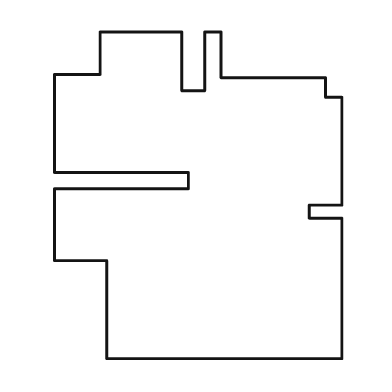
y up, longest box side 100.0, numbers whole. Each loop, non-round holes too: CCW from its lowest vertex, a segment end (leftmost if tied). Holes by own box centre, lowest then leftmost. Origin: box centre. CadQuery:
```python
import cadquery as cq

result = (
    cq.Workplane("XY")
    .moveTo(-28.0, -50.0)
    .lineTo(44.0, -50.0)
    .lineTo(44.0, -7.0)
    .lineTo(34.0, -7.0)
    .lineTo(34.0, -3.0)
    .lineTo(44.0, -3.0)
    .lineTo(44.0, 30.0)
    .lineTo(39.0, 30.0)
    .lineTo(39.0, 36.0)
    .lineTo(7.0, 36.0)
    .lineTo(7.0, 50.0)
    .lineTo(2.0, 50.0)
    .lineTo(2.0, 32.0)
    .lineTo(-5.0, 32.0)
    .lineTo(-5.0, 50.0)
    .lineTo(-30.0, 50.0)
    .lineTo(-30.0, 37.0)
    .lineTo(-44.0, 37.0)
    .lineTo(-44.0, 7.0)
    .lineTo(-3.0, 7.0)
    .lineTo(-3.0, 2.0)
    .lineTo(-44.0, 2.0)
    .lineTo(-44.0, -20.0)
    .lineTo(-28.0, -20.0)
    .close()
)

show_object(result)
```